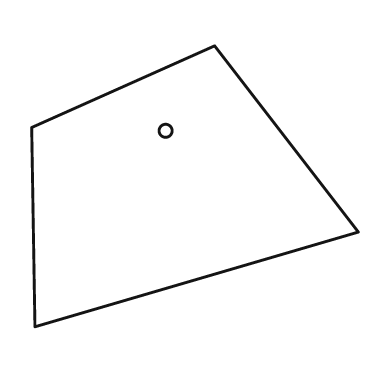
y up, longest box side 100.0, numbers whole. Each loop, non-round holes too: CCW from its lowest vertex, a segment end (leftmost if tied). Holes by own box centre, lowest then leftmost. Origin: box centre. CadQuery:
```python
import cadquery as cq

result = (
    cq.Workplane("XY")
    .moveTo(-49.0, -43.0)
    .lineTo(50.0, -14.0)
    .lineTo(6.0, 43.0)
    .lineTo(-50.0, 18.0)
    .close()
    .moveTo(-9.0, 17.0)
    .circle(2.0)
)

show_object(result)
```